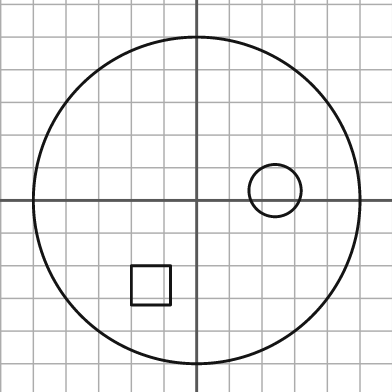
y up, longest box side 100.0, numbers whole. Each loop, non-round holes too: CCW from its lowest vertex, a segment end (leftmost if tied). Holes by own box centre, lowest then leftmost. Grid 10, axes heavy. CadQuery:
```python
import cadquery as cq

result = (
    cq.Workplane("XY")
    .moveTo(0.0, 0.0)
    .circle(50.0)
    .moveTo(-20.0, -32.0)
    .lineTo(-8.0, -32.0)
    .lineTo(-8.0, -20.0)
    .lineTo(-20.0, -20.0)
    .close()
    .moveTo(24.0, 3.0)
    .circle(8.0)
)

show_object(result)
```